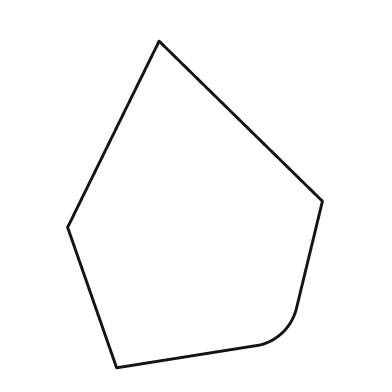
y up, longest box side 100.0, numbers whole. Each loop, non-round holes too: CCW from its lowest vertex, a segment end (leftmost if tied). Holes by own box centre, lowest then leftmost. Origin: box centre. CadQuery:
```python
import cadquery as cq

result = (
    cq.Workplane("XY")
    .moveTo(-24.0, -50.0)
    .lineTo(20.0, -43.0)
    .threePointArc((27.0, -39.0), (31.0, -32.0))
    .lineTo(39.0, 1.0)
    .lineTo(-11.0, 50.0)
    .lineTo(-39.0, -7.0)
    .close()
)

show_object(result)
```